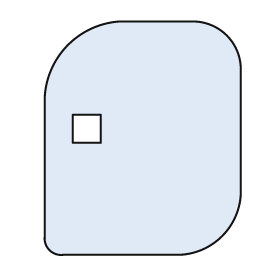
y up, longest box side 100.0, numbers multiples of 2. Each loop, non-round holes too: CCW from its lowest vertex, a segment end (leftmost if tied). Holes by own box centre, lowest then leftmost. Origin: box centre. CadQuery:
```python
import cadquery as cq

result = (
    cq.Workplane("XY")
    .moveTo(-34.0, -50.0)
    .lineTo(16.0, -50.0)
    .threePointArc((34.0, -42.0), (42.0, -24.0))
    .lineTo(42.0, 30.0)
    .threePointArc((36.0, 44.0), (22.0, 50.0))
    .lineTo(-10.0, 50.0)
    .threePointArc((-32.0, 40.0), (-42.0, 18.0))
    .lineTo(-42.0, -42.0)
    .threePointArc((-40.0, -48.0), (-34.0, -50.0))
    .close()
    .moveTo(-30.0, -2.0)
    .lineTo(-18.0, -2.0)
    .lineTo(-18.0, 10.0)
    .lineTo(-30.0, 10.0)
    .close()
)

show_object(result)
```